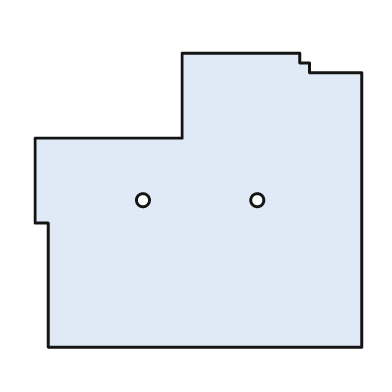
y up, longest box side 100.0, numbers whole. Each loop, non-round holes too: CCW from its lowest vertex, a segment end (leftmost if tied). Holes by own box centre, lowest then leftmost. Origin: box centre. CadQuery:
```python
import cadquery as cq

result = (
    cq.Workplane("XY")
    .moveTo(-46.0, -45.0)
    .lineTo(50.0, -45.0)
    .lineTo(50.0, 39.0)
    .lineTo(34.0, 39.0)
    .lineTo(34.0, 42.0)
    .lineTo(31.0, 42.0)
    .lineTo(31.0, 45.0)
    .lineTo(-5.0, 45.0)
    .lineTo(-5.0, 19.0)
    .lineTo(-50.0, 19.0)
    .lineTo(-50.0, -7.0)
    .lineTo(-46.0, -7.0)
    .close()
    .moveTo(-17.0, 0.0)
    .circle(2.0)
    .moveTo(18.0, 0.0)
    .circle(2.0)
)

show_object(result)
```